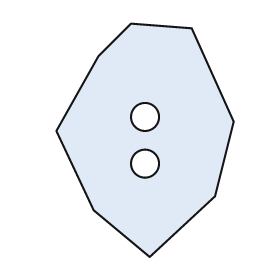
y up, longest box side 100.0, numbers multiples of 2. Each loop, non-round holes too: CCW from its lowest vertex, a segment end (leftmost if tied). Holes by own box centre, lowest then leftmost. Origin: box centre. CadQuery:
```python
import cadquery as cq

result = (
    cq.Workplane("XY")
    .moveTo(2.0, -50.0)
    .lineTo(30.0, -24.0)
    .lineTo(38.0, 8.0)
    .lineTo(20.0, 48.0)
    .lineTo(-6.0, 50.0)
    .lineTo(-20.0, 36.0)
    .lineTo(-38.0, 4.0)
    .lineTo(-22.0, -30.0)
    .close()
    .moveTo(0.0, -10.0)
    .circle(6.0)
    .moveTo(0.0, 10.0)
    .circle(6.0)
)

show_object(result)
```